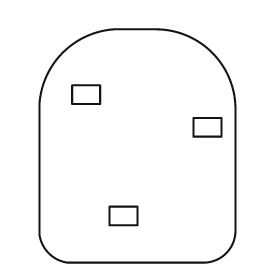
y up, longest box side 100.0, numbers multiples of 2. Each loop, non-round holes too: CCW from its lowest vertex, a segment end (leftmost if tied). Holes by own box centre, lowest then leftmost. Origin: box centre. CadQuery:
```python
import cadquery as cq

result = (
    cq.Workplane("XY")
    .moveTo(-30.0, -50.0)
    .lineTo(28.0, -50.0)
    .threePointArc((38.0, -46.0), (42.0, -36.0))
    .lineTo(42.0, 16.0)
    .threePointArc((32.0, 40.0), (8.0, 50.0))
    .lineTo(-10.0, 50.0)
    .threePointArc((-32.0, 40.0), (-42.0, 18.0))
    .lineTo(-42.0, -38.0)
    .threePointArc((-38.0, -46.0), (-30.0, -50.0))
    .close()
    .moveTo(-12.0, -34.0)
    .lineTo(0.0, -34.0)
    .lineTo(0.0, -26.0)
    .lineTo(-12.0, -26.0)
    .close()
    .moveTo(24.0, 4.0)
    .lineTo(36.0, 4.0)
    .lineTo(36.0, 12.0)
    .lineTo(24.0, 12.0)
    .close()
    .moveTo(-28.0, 18.0)
    .lineTo(-16.0, 18.0)
    .lineTo(-16.0, 26.0)
    .lineTo(-28.0, 26.0)
    .close()
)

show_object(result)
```